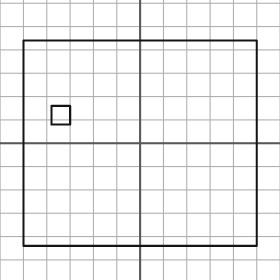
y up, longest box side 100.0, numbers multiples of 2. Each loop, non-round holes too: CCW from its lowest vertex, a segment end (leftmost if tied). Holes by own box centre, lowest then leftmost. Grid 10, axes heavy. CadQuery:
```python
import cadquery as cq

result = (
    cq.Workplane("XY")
    .moveTo(-50.0, -44.0)
    .lineTo(50.0, -44.0)
    .lineTo(50.0, 44.0)
    .lineTo(-50.0, 44.0)
    .close()
    .moveTo(-38.0, 8.0)
    .lineTo(-30.0, 8.0)
    .lineTo(-30.0, 16.0)
    .lineTo(-38.0, 16.0)
    .close()
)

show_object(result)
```